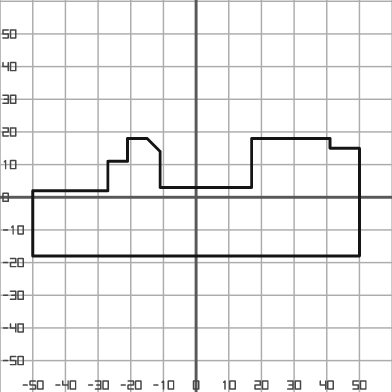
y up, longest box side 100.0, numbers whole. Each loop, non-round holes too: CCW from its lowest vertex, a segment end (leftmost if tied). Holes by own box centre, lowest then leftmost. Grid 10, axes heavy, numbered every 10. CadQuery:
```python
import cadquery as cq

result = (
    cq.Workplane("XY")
    .moveTo(-50.0, -18.0)
    .lineTo(50.0, -18.0)
    .lineTo(50.0, 15.0)
    .lineTo(41.0, 15.0)
    .lineTo(41.0, 18.0)
    .lineTo(17.0, 18.0)
    .lineTo(17.0, 3.0)
    .lineTo(-11.0, 3.0)
    .lineTo(-11.0, 14.0)
    .lineTo(-15.0, 18.0)
    .lineTo(-21.0, 18.0)
    .lineTo(-21.0, 11.0)
    .lineTo(-27.0, 11.0)
    .lineTo(-27.0, 2.0)
    .lineTo(-50.0, 2.0)
    .close()
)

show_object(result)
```